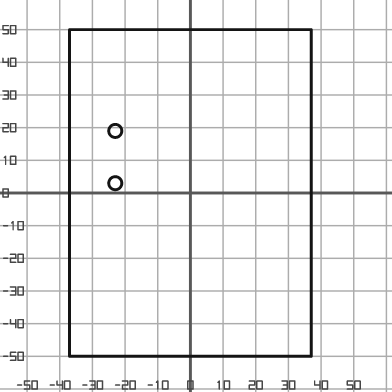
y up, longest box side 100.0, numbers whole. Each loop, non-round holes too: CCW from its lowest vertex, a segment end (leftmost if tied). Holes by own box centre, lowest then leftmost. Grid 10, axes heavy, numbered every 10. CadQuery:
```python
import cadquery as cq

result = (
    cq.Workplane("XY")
    .moveTo(-37.0, -50.0)
    .lineTo(37.0, -50.0)
    .lineTo(37.0, 50.0)
    .lineTo(-37.0, 50.0)
    .close()
    .moveTo(-23.0, 3.0)
    .circle(2.0)
    .moveTo(-23.0, 19.0)
    .circle(2.0)
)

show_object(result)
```